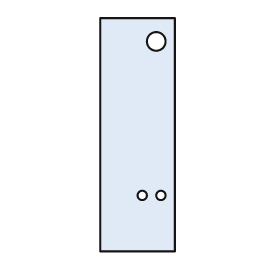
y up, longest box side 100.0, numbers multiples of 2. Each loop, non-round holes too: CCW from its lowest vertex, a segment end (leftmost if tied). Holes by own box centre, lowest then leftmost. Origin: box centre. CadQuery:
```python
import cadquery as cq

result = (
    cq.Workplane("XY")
    .moveTo(-16.0, -50.0)
    .lineTo(16.0, -50.0)
    .lineTo(16.0, 50.0)
    .lineTo(-16.0, 50.0)
    .close()
    .moveTo(2.0, -26.0)
    .circle(2.0)
    .moveTo(10.0, -26.0)
    .circle(2.0)
    .moveTo(8.0, 40.0)
    .circle(4.0)
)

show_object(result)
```